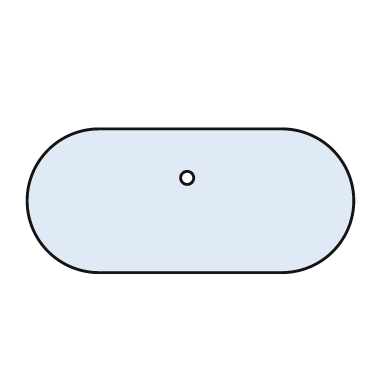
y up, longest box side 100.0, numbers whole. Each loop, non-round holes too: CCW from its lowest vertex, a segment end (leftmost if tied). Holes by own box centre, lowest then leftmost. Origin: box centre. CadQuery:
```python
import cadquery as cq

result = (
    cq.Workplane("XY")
    .moveTo(-28.0, -22.0)
    .lineTo(28.0, -22.0)
    .threePointArc((50.0, 0.0), (28.0, 22.0))
    .lineTo(-28.0, 22.0)
    .threePointArc((-50.0, 0.0), (-28.0, -22.0))
    .close()
    .moveTo(-1.0, 7.0)
    .circle(2.0)
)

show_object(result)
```